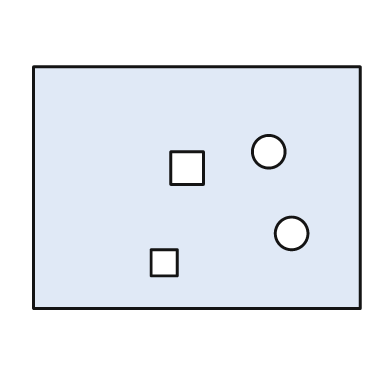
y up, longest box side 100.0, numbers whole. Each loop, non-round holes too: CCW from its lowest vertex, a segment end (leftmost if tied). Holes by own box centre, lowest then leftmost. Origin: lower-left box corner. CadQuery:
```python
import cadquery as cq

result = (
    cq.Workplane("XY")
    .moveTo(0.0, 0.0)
    .lineTo(100.0, 0.0)
    .lineTo(100.0, 74.0)
    .lineTo(0.0, 74.0)
    .close()
    .moveTo(36.0, 10.0)
    .lineTo(44.0, 10.0)
    .lineTo(44.0, 18.0)
    .lineTo(36.0, 18.0)
    .close()
    .moveTo(79.0, 23.0)
    .circle(5.0)
    .moveTo(42.0, 38.0)
    .lineTo(52.0, 38.0)
    .lineTo(52.0, 48.0)
    .lineTo(42.0, 48.0)
    .close()
    .moveTo(72.0, 48.0)
    .circle(5.0)
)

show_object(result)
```